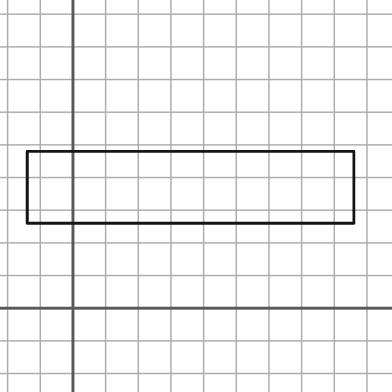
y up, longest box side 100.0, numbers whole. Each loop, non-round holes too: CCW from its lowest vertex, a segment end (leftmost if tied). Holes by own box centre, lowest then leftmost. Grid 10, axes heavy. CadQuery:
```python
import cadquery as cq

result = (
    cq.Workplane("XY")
    .moveTo(-14.0, 26.0)
    .lineTo(86.0, 26.0)
    .lineTo(86.0, 48.0)
    .lineTo(-14.0, 48.0)
    .close()
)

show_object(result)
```